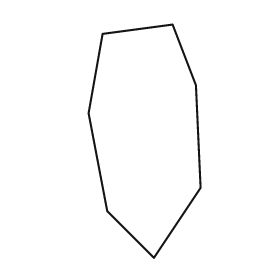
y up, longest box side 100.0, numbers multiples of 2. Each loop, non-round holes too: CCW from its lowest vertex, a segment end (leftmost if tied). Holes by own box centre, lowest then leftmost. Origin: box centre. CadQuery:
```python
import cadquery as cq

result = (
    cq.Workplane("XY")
    .moveTo(4.0, -50.0)
    .lineTo(24.0, -20.0)
    .lineTo(22.0, 24.0)
    .lineTo(12.0, 50.0)
    .lineTo(-18.0, 46.0)
    .lineTo(-24.0, 12.0)
    .lineTo(-16.0, -30.0)
    .close()
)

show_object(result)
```